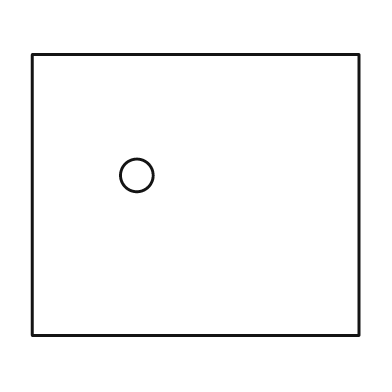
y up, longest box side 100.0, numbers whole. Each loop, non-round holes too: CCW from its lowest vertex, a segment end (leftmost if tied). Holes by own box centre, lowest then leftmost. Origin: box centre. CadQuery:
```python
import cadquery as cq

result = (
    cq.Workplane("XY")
    .moveTo(-50.0, -43.0)
    .lineTo(50.0, -43.0)
    .lineTo(50.0, 43.0)
    .lineTo(-50.0, 43.0)
    .close()
    .moveTo(-18.0, 6.0)
    .circle(5.0)
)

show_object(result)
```